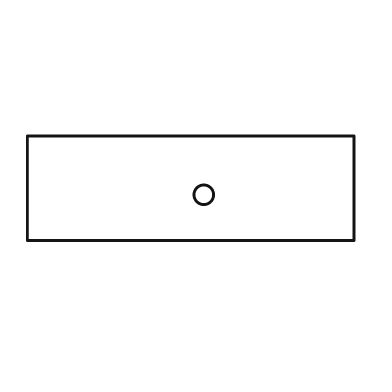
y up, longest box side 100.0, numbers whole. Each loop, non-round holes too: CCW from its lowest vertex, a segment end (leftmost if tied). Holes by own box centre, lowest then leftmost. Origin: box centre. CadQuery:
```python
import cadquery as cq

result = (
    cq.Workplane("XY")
    .moveTo(-50.0, -16.0)
    .lineTo(50.0, -16.0)
    .lineTo(50.0, 16.0)
    .lineTo(-50.0, 16.0)
    .close()
    .moveTo(4.0, -2.0)
    .circle(3.0)
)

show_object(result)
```